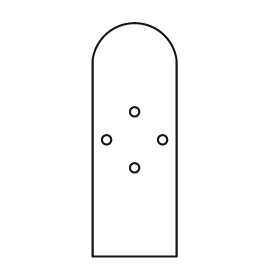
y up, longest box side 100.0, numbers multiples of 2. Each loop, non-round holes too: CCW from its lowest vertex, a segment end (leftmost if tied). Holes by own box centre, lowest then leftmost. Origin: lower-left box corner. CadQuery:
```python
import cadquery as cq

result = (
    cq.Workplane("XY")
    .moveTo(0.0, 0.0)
    .lineTo(36.0, 0.0)
    .lineTo(36.0, 84.0)
    .threePointArc((18.0, 100.0), (0.0, 84.0))
    .close()
    .moveTo(18.0, 38.0)
    .circle(2.0)
    .moveTo(6.0, 50.0)
    .circle(2.0)
    .moveTo(30.0, 50.0)
    .circle(2.0)
    .moveTo(18.0, 62.0)
    .circle(2.0)
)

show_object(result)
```